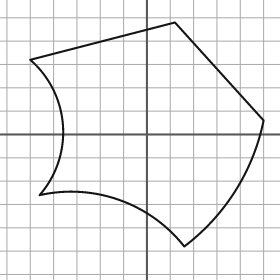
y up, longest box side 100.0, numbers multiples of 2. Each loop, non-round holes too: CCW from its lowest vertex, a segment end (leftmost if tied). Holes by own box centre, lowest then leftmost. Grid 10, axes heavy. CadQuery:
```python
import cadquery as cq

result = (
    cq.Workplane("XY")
    .moveTo(16.0, -48.0)
    .threePointArc((38.0, -24.0), (50.0, 6.0))
    .lineTo(12.0, 48.0)
    .lineTo(-50.0, 32.0)
    .threePointArc((-36.0, 4.0), (-46.0, -26.0))
    .threePointArc((-12.0, -28.0), (16.0, -48.0))
    .close()
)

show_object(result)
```